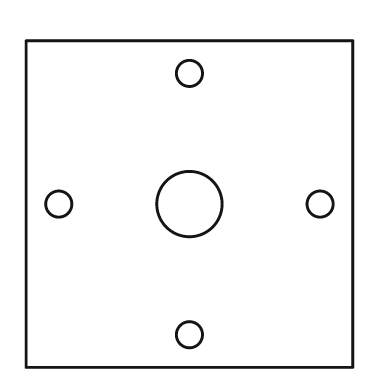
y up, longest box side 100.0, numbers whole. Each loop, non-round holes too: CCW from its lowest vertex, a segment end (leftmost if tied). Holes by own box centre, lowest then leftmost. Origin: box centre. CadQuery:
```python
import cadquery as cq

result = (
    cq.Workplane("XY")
    .moveTo(-50.0, -50.0)
    .lineTo(50.0, -50.0)
    .lineTo(50.0, 50.0)
    .lineTo(-50.0, 50.0)
    .close()
    .moveTo(0.0, -40.0)
    .circle(4.0)
    .moveTo(-40.0, 0.0)
    .circle(4.0)
    .moveTo(0.0, 0.0)
    .circle(10.0)
    .moveTo(40.0, 0.0)
    .circle(4.0)
    .moveTo(0.0, 40.0)
    .circle(4.0)
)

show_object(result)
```